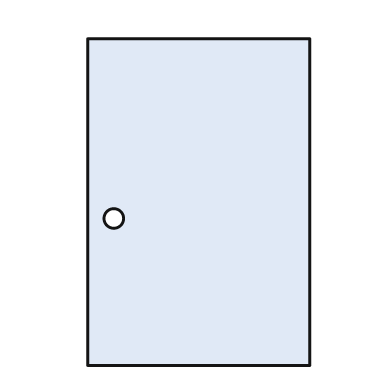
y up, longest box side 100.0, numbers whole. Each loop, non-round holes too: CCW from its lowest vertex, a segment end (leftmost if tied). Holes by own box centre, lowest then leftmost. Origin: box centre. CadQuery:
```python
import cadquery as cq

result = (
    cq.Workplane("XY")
    .moveTo(-34.0, -50.0)
    .lineTo(34.0, -50.0)
    .lineTo(34.0, 50.0)
    .lineTo(-34.0, 50.0)
    .close()
    .moveTo(-26.0, -5.0)
    .circle(3.0)
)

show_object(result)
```